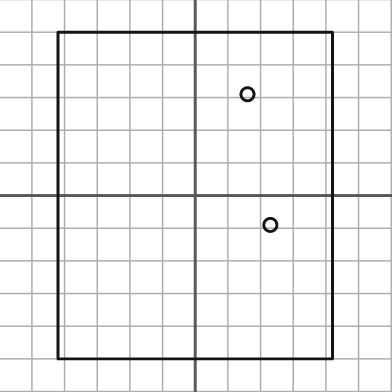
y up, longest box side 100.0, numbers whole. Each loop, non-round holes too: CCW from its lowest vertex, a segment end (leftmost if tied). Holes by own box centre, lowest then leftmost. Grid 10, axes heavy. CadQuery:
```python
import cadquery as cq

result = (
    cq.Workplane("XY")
    .moveTo(-42.0, -50.0)
    .lineTo(42.0, -50.0)
    .lineTo(42.0, 50.0)
    .lineTo(-42.0, 50.0)
    .close()
    .moveTo(23.0, -9.0)
    .circle(2.0)
    .moveTo(16.0, 31.0)
    .circle(2.0)
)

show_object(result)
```